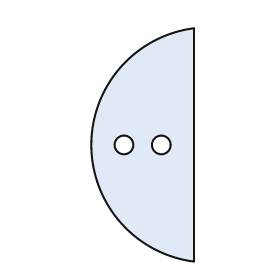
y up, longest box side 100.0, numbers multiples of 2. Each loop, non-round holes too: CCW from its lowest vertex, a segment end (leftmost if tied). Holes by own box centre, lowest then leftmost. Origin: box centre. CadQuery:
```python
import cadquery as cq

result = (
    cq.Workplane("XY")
    .moveTo(22.0, -50.0)
    .lineTo(22.0, 50.0)
    .threePointArc((-22.0, 0.0), (22.0, -50.0))
    .close()
    .moveTo(-8.0, 0.0)
    .circle(4.0)
    .moveTo(8.0, 0.0)
    .circle(4.0)
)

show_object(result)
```